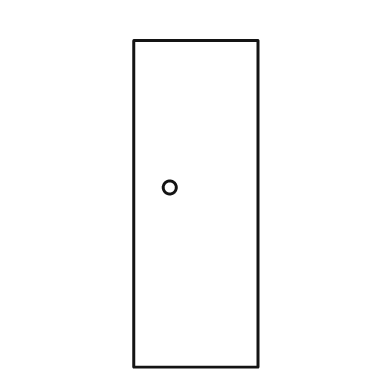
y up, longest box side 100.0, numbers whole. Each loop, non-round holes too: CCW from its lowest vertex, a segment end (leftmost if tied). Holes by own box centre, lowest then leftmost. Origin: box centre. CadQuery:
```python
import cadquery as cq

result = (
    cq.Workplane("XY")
    .moveTo(-19.0, -50.0)
    .lineTo(19.0, -50.0)
    .lineTo(19.0, 50.0)
    .lineTo(-19.0, 50.0)
    .close()
    .moveTo(-8.0, 5.0)
    .circle(2.0)
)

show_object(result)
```